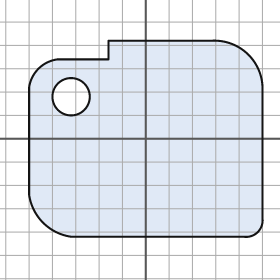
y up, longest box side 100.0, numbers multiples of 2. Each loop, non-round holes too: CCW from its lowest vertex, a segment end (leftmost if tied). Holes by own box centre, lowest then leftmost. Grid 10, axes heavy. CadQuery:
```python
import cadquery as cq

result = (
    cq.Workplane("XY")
    .moveTo(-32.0, -42.0)
    .lineTo(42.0, -42.0)
    .threePointArc((48.0, -40.0), (50.0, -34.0))
    .lineTo(50.0, 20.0)
    .threePointArc((44.0, 36.0), (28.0, 42.0))
    .lineTo(-16.0, 42.0)
    .lineTo(-16.0, 34.0)
    .lineTo(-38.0, 34.0)
    .threePointArc((-46.0, 30.0), (-50.0, 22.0))
    .lineTo(-50.0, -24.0)
    .threePointArc((-44.0, -36.0), (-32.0, -42.0))
    .close()
    .moveTo(-32.0, 18.0)
    .circle(8.0)
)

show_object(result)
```